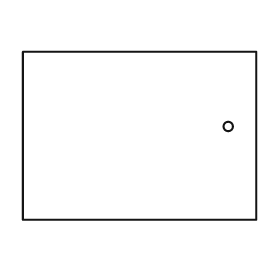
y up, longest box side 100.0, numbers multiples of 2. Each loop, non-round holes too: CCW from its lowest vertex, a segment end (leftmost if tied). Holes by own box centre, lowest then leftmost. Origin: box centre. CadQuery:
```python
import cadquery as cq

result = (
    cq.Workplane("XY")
    .moveTo(-50.0, -36.0)
    .lineTo(50.0, -36.0)
    .lineTo(50.0, 36.0)
    .lineTo(-50.0, 36.0)
    .close()
    .moveTo(38.0, 4.0)
    .circle(2.0)
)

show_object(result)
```